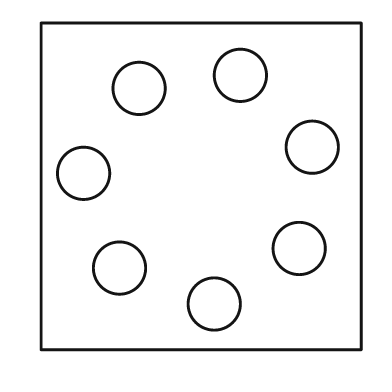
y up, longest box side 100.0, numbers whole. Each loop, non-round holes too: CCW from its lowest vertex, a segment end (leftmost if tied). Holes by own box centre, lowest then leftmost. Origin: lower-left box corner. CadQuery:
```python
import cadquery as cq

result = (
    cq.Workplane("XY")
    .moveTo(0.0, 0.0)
    .lineTo(98.0, 0.0)
    .lineTo(98.0, 100.0)
    .lineTo(0.0, 100.0)
    .close()
    .moveTo(53.0, 14.0)
    .circle(8.0)
    .moveTo(24.0, 25.0)
    .circle(8.0)
    .moveTo(79.0, 31.0)
    .circle(8.0)
    .moveTo(13.0, 54.0)
    .circle(8.0)
    .moveTo(83.0, 62.0)
    .circle(8.0)
    .moveTo(30.0, 80.0)
    .circle(8.0)
    .moveTo(61.0, 84.0)
    .circle(8.0)
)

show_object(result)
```